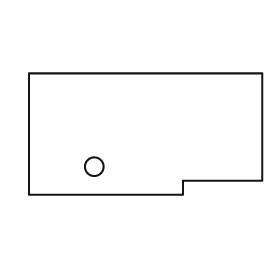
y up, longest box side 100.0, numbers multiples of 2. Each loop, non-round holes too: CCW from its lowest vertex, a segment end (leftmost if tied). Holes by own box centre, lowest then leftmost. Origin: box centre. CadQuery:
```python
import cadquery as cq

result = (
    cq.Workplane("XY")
    .moveTo(-50.0, -26.0)
    .lineTo(16.0, -26.0)
    .lineTo(16.0, -20.0)
    .lineTo(50.0, -20.0)
    .lineTo(50.0, 26.0)
    .lineTo(-50.0, 26.0)
    .close()
    .moveTo(-22.0, -14.0)
    .circle(4.0)
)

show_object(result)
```